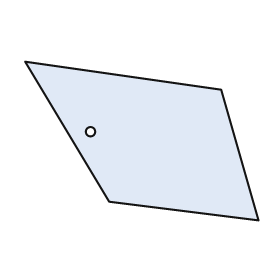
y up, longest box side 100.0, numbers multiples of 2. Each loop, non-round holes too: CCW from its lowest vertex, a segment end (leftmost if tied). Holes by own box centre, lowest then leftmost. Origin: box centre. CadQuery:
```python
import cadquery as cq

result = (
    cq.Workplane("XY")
    .moveTo(50.0, -34.0)
    .lineTo(34.0, 22.0)
    .lineTo(-50.0, 34.0)
    .lineTo(-14.0, -26.0)
    .close()
    .moveTo(-22.0, 4.0)
    .circle(2.0)
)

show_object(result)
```